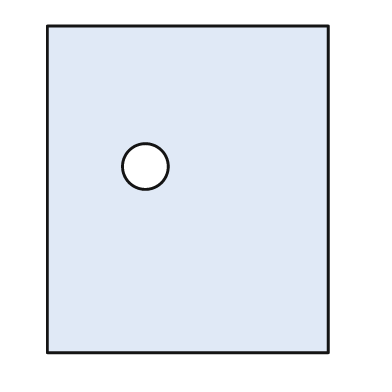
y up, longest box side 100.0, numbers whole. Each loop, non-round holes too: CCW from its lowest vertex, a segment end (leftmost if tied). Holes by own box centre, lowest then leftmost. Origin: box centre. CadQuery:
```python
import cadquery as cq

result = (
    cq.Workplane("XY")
    .moveTo(-43.0, -50.0)
    .lineTo(43.0, -50.0)
    .lineTo(43.0, 50.0)
    .lineTo(-43.0, 50.0)
    .close()
    .moveTo(-13.0, 7.0)
    .circle(7.0)
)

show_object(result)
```